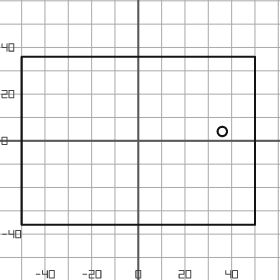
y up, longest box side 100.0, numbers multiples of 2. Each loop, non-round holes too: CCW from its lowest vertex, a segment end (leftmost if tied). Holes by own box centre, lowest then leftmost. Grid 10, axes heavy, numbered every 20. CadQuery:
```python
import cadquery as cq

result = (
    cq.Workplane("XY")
    .moveTo(-50.0, -36.0)
    .lineTo(50.0, -36.0)
    .lineTo(50.0, 36.0)
    .lineTo(-50.0, 36.0)
    .close()
    .moveTo(36.0, 4.0)
    .circle(2.0)
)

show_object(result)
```